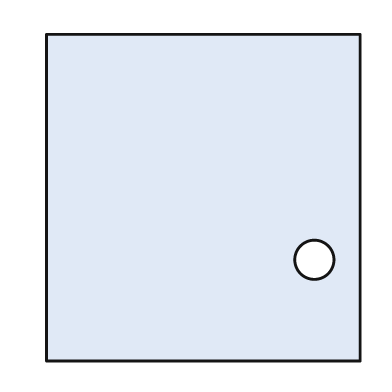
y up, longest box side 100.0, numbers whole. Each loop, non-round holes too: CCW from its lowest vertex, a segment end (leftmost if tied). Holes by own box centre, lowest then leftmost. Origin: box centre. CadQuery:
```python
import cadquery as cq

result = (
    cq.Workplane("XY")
    .moveTo(-48.0, -50.0)
    .lineTo(48.0, -50.0)
    .lineTo(48.0, 50.0)
    .lineTo(-48.0, 50.0)
    .close()
    .moveTo(34.0, -19.0)
    .circle(6.0)
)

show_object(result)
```